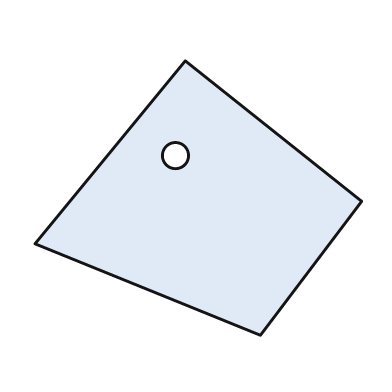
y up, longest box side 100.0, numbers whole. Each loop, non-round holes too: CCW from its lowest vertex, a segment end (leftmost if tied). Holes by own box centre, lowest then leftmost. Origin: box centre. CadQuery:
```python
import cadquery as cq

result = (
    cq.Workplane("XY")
    .moveTo(19.0, -42.0)
    .lineTo(50.0, -1.0)
    .lineTo(-4.0, 42.0)
    .lineTo(-50.0, -14.0)
    .close()
    .moveTo(-7.0, 13.0)
    .circle(4.0)
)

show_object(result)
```